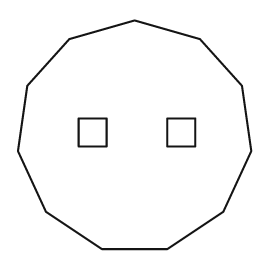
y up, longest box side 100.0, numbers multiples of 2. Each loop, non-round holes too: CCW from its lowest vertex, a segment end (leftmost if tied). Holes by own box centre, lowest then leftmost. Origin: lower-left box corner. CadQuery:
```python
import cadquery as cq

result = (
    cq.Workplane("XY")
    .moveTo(36.0, 0.0)
    .lineTo(64.0, 0.0)
    .lineTo(88.0, 16.0)
    .lineTo(100.0, 42.0)
    .lineTo(96.0, 70.0)
    .lineTo(78.0, 90.0)
    .lineTo(50.0, 98.0)
    .lineTo(22.0, 90.0)
    .lineTo(4.0, 70.0)
    .lineTo(0.0, 42.0)
    .lineTo(12.0, 16.0)
    .close()
    .moveTo(26.0, 44.0)
    .lineTo(38.0, 44.0)
    .lineTo(38.0, 56.0)
    .lineTo(26.0, 56.0)
    .close()
    .moveTo(64.0, 44.0)
    .lineTo(76.0, 44.0)
    .lineTo(76.0, 56.0)
    .lineTo(64.0, 56.0)
    .close()
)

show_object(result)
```